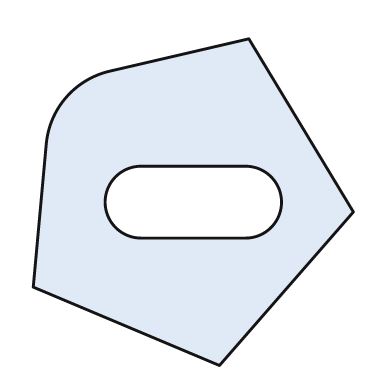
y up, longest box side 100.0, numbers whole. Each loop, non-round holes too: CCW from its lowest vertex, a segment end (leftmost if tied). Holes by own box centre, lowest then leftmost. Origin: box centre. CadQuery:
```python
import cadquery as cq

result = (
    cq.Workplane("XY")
    .moveTo(8.0, -50.0)
    .lineTo(49.0, -3.0)
    .lineTo(17.0, 50.0)
    .lineTo(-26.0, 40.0)
    .threePointArc((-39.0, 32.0), (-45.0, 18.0))
    .lineTo(-49.0, -26.0)
    .close()
    .moveTo(-16.0, -11.0)
    .lineTo(16.0, -11.0)
    .threePointArc((27.0, 0.0), (16.0, 11.0))
    .lineTo(-16.0, 11.0)
    .threePointArc((-27.0, 0.0), (-16.0, -11.0))
    .close()
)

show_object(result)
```